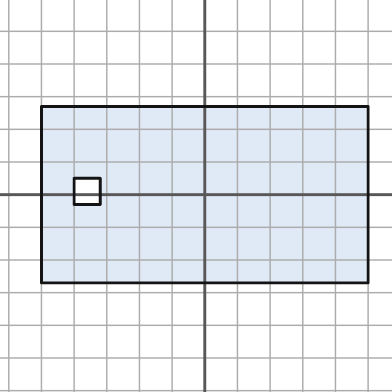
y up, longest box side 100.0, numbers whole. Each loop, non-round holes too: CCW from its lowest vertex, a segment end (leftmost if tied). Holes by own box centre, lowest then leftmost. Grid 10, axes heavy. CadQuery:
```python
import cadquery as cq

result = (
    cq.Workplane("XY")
    .moveTo(-50.0, -27.0)
    .lineTo(50.0, -27.0)
    .lineTo(50.0, 27.0)
    .lineTo(-50.0, 27.0)
    .close()
    .moveTo(-40.0, -3.0)
    .lineTo(-32.0, -3.0)
    .lineTo(-32.0, 5.0)
    .lineTo(-40.0, 5.0)
    .close()
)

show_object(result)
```